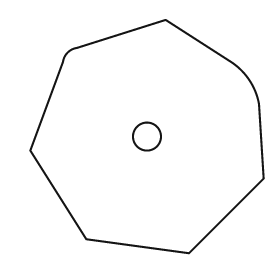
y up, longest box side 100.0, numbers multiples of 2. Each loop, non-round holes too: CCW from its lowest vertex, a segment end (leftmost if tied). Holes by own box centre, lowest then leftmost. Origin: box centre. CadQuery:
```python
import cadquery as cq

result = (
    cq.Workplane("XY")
    .moveTo(18.0, -50.0)
    .lineTo(50.0, -18.0)
    .lineTo(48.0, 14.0)
    .threePointArc((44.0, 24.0), (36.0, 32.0))
    .lineTo(8.0, 50.0)
    .lineTo(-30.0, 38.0)
    .threePointArc((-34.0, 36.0), (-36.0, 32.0))
    .lineTo(-50.0, -6.0)
    .lineTo(-26.0, -44.0)
    .close()
    .moveTo(0.0, 0.0)
    .circle(6.0)
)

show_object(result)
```